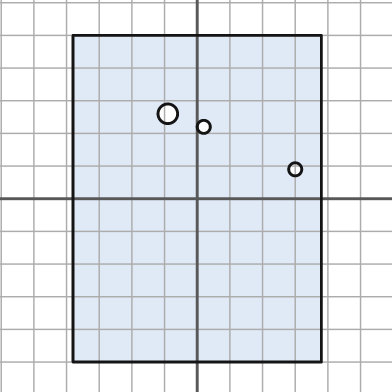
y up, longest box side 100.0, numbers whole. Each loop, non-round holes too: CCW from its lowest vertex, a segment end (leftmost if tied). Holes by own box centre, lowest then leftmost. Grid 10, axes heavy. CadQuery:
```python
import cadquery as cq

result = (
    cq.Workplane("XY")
    .moveTo(-38.0, -50.0)
    .lineTo(38.0, -50.0)
    .lineTo(38.0, 50.0)
    .lineTo(-38.0, 50.0)
    .close()
    .moveTo(30.0, 9.0)
    .circle(2.0)
    .moveTo(2.0, 22.0)
    .circle(2.0)
    .moveTo(-9.0, 26.0)
    .circle(3.0)
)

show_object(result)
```